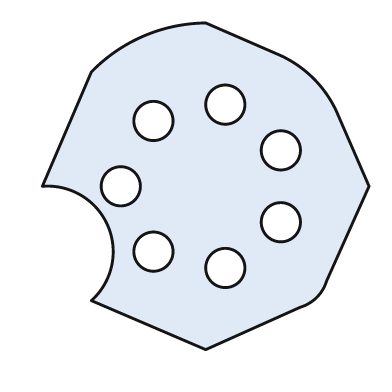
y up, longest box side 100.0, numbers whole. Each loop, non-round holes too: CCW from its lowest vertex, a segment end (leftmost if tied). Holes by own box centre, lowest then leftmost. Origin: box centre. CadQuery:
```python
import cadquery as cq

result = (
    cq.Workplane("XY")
    .moveTo(0.0, -50.0)
    .lineTo(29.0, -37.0)
    .threePointArc((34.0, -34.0), (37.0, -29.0))
    .lineTo(50.0, 0.0)
    .lineTo(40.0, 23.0)
    .threePointArc((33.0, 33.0), (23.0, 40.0))
    .lineTo(0.0, 50.0)
    .threePointArc((-19.0, 46.0), (-35.0, 35.0))
    .lineTo(-50.0, 0.0)
    .threePointArc((-30.0, -12.0), (-35.0, -35.0))
    .close()
    .moveTo(6.0, -25.0)
    .circle(6.0)
    .moveTo(-16.0, -20.0)
    .circle(6.0)
    .moveTo(23.0, -11.0)
    .circle(6.0)
    .moveTo(-26.0, 0.0)
    .circle(6.0)
    .moveTo(23.0, 11.0)
    .circle(6.0)
    .moveTo(-16.0, 20.0)
    .circle(6.0)
    .moveTo(6.0, 25.0)
    .circle(6.0)
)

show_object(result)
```